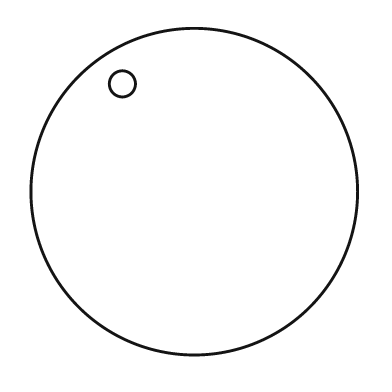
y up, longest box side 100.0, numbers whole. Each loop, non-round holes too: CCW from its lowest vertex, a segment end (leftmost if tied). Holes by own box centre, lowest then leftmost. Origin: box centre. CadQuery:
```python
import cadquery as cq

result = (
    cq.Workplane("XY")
    .moveTo(0.0, 0.0)
    .circle(50.0)
    .moveTo(-22.0, 33.0)
    .circle(4.0)
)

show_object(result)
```